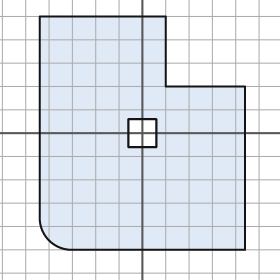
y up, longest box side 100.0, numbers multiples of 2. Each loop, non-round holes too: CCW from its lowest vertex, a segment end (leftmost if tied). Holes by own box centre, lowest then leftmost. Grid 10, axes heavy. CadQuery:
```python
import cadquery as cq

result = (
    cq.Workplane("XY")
    .moveTo(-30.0, -50.0)
    .lineTo(44.0, -50.0)
    .lineTo(44.0, 20.0)
    .lineTo(10.0, 20.0)
    .lineTo(10.0, 50.0)
    .lineTo(-44.0, 50.0)
    .lineTo(-44.0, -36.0)
    .threePointArc((-40.0, -46.0), (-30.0, -50.0))
    .close()
    .moveTo(-6.0, -6.0)
    .lineTo(6.0, -6.0)
    .lineTo(6.0, 6.0)
    .lineTo(-6.0, 6.0)
    .close()
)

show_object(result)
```